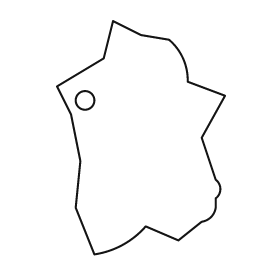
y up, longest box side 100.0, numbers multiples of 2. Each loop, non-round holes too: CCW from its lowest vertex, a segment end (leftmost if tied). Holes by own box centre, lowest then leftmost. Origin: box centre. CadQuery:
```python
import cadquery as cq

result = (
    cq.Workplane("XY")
    .moveTo(-20.0, -50.0)
    .threePointArc((-8.0, -46.0), (2.0, -38.0))
    .lineTo(16.0, -44.0)
    .lineTo(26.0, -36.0)
    .threePointArc((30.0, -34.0), (32.0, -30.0))
    .lineTo(32.0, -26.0)
    .threePointArc((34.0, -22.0), (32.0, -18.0))
    .lineTo(26.0, 0.0)
    .lineTo(36.0, 18.0)
    .lineTo(20.0, 24.0)
    .threePointArc((18.0, 34.0), (12.0, 42.0))
    .lineTo(0.0, 44.0)
    .lineTo(-12.0, 50.0)
    .lineTo(-16.0, 34.0)
    .lineTo(-36.0, 22.0)
    .lineTo(-30.0, 10.0)
    .lineTo(-26.0, -10.0)
    .lineTo(-28.0, -30.0)
    .close()
    .moveTo(-24.0, 16.0)
    .circle(4.0)
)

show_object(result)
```